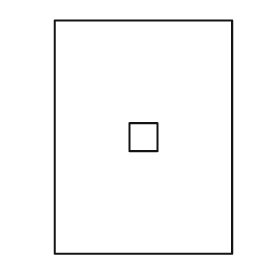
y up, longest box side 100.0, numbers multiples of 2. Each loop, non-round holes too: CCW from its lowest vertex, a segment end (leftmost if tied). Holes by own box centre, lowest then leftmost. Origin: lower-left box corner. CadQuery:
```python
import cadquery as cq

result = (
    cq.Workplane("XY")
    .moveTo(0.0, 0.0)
    .lineTo(76.0, 0.0)
    .lineTo(76.0, 100.0)
    .lineTo(0.0, 100.0)
    .close()
    .moveTo(32.0, 44.0)
    .lineTo(44.0, 44.0)
    .lineTo(44.0, 56.0)
    .lineTo(32.0, 56.0)
    .close()
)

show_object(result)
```